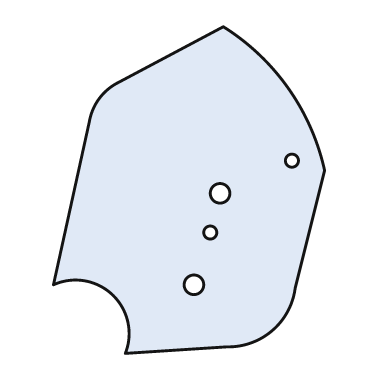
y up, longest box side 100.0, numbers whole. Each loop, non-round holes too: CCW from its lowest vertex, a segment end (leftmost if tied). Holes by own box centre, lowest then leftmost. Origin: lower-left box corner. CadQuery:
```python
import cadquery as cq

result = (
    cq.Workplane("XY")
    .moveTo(22.0, 0.0)
    .lineTo(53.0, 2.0)
    .threePointArc((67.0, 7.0), (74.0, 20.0))
    .lineTo(83.0, 56.0)
    .threePointArc((72.0, 81.0), (52.0, 100.0))
    .lineTo(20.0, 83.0)
    .threePointArc((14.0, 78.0), (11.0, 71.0))
    .lineTo(0.0, 21.0)
    .threePointArc((18.0, 18.0), (22.0, 0.0))
    .close()
    .moveTo(43.0, 21.0)
    .circle(3.0)
    .moveTo(48.0, 37.0)
    .circle(2.0)
    .moveTo(51.0, 49.0)
    .circle(3.0)
    .moveTo(73.0, 59.0)
    .circle(2.0)
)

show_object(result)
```